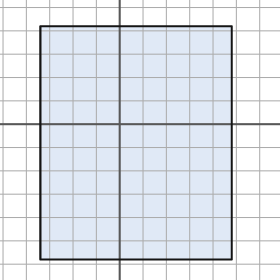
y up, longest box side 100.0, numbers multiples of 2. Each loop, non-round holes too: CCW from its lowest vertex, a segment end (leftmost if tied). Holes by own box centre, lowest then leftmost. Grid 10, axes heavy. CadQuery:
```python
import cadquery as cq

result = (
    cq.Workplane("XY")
    .moveTo(-34.0, -58.0)
    .lineTo(48.0, -58.0)
    .lineTo(48.0, 42.0)
    .lineTo(-34.0, 42.0)
    .close()
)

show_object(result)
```